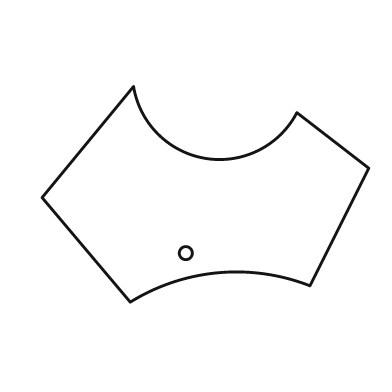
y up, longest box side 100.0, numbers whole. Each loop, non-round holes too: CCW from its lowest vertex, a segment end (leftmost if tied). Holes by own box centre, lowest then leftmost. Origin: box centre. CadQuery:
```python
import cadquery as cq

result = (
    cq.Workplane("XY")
    .moveTo(-23.0, -33.0)
    .threePointArc((4.0, -24.0), (32.0, -28.0))
    .lineTo(50.0, 8.0)
    .lineTo(28.0, 25.0)
    .threePointArc((0.0, 11.0), (-22.0, 33.0))
    .lineTo(-50.0, -1.0)
    .close()
    .moveTo(-6.0, -18.0)
    .circle(2.0)
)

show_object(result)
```